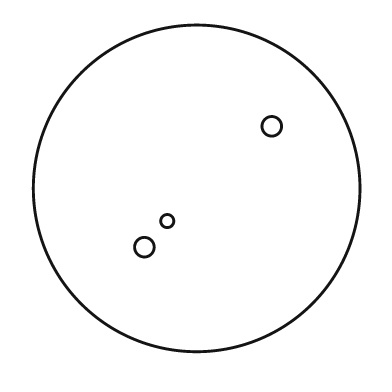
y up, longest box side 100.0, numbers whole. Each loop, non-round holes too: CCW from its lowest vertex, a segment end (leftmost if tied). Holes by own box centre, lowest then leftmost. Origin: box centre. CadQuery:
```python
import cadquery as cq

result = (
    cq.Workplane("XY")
    .moveTo(0.0, 0.0)
    .circle(50.0)
    .moveTo(-16.0, -18.0)
    .circle(3.0)
    .moveTo(-9.0, -10.0)
    .circle(2.0)
    .moveTo(23.0, 19.0)
    .circle(3.0)
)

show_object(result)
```